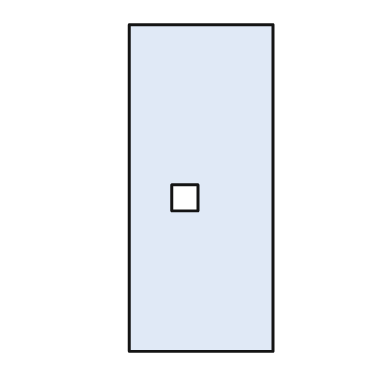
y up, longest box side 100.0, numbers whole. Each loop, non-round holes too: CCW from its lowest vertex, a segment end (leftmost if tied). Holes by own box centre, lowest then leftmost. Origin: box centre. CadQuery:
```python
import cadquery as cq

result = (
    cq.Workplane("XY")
    .moveTo(-22.0, -50.0)
    .lineTo(22.0, -50.0)
    .lineTo(22.0, 50.0)
    .lineTo(-22.0, 50.0)
    .close()
    .moveTo(-9.0, -7.0)
    .lineTo(-1.0, -7.0)
    .lineTo(-1.0, 1.0)
    .lineTo(-9.0, 1.0)
    .close()
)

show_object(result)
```